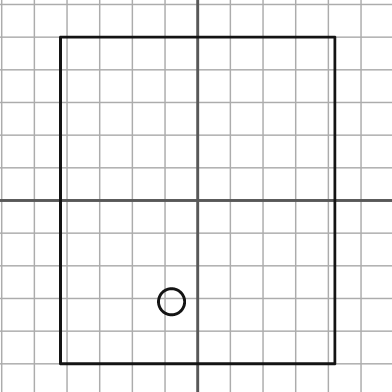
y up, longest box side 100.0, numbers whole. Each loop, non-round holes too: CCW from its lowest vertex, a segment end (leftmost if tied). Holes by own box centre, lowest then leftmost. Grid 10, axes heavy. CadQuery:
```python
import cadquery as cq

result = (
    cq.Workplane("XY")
    .moveTo(-42.0, -50.0)
    .lineTo(42.0, -50.0)
    .lineTo(42.0, 50.0)
    .lineTo(-42.0, 50.0)
    .close()
    .moveTo(-8.0, -31.0)
    .circle(4.0)
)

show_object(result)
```